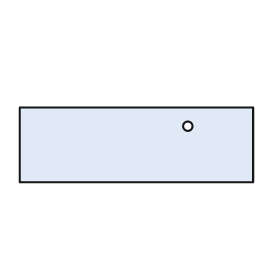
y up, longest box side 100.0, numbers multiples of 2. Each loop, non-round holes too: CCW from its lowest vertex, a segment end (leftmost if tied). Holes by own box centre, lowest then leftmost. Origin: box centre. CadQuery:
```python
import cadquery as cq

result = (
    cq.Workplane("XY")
    .moveTo(-50.0, -16.0)
    .lineTo(50.0, -16.0)
    .lineTo(50.0, 16.0)
    .lineTo(-50.0, 16.0)
    .close()
    .moveTo(22.0, 8.0)
    .circle(2.0)
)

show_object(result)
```